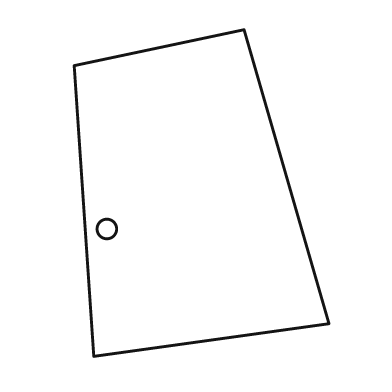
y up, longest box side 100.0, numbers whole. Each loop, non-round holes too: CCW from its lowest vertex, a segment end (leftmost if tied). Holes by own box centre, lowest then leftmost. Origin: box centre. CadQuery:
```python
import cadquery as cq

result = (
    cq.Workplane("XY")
    .moveTo(-33.0, -50.0)
    .lineTo(39.0, -40.0)
    .lineTo(13.0, 50.0)
    .lineTo(-39.0, 39.0)
    .close()
    .moveTo(-29.0, -11.0)
    .circle(3.0)
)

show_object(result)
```